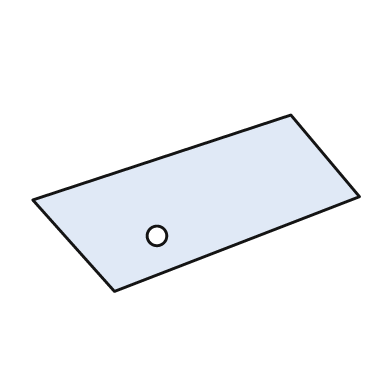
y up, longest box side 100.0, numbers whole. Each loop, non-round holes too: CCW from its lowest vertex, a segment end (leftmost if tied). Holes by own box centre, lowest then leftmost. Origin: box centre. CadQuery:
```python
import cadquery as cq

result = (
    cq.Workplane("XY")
    .moveTo(-25.0, -27.0)
    .lineTo(50.0, 2.0)
    .lineTo(29.0, 27.0)
    .lineTo(-50.0, 1.0)
    .close()
    .moveTo(-12.0, -10.0)
    .circle(3.0)
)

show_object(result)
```